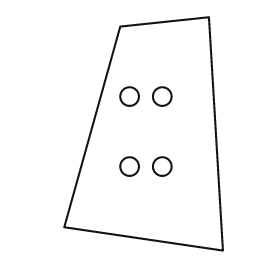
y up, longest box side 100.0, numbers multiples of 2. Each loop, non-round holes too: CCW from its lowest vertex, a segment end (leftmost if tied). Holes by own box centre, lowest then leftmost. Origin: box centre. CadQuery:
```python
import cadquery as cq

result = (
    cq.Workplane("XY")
    .moveTo(34.0, -50.0)
    .lineTo(28.0, 50.0)
    .lineTo(-10.0, 46.0)
    .lineTo(-34.0, -40.0)
    .close()
    .moveTo(-6.0, -14.0)
    .circle(4.0)
    .moveTo(8.0, -14.0)
    .circle(4.0)
    .moveTo(-6.0, 16.0)
    .circle(4.0)
    .moveTo(8.0, 16.0)
    .circle(4.0)
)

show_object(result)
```